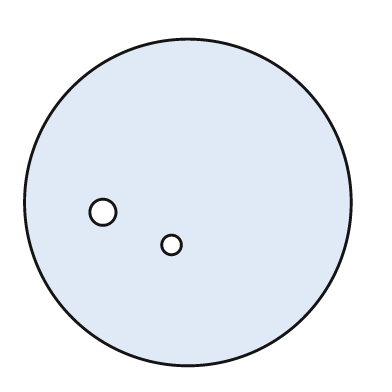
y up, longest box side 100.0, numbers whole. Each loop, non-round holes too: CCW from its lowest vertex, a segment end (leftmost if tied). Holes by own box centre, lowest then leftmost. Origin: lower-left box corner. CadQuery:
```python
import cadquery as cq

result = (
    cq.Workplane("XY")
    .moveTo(50.0, 50.0)
    .circle(50.0)
    .moveTo(45.0, 37.0)
    .circle(3.0)
    .moveTo(24.0, 47.0)
    .circle(4.0)
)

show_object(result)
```